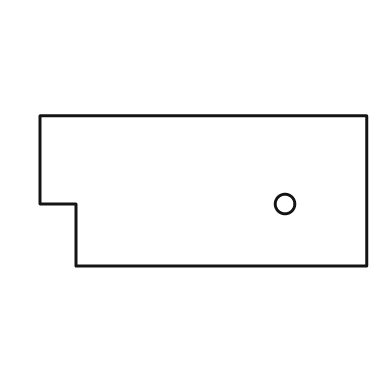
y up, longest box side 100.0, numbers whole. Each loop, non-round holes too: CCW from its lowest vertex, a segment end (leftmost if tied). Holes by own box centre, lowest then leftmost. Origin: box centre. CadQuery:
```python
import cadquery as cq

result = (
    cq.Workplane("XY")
    .moveTo(-39.0, -23.0)
    .lineTo(50.0, -23.0)
    .lineTo(50.0, 23.0)
    .lineTo(-50.0, 23.0)
    .lineTo(-50.0, -4.0)
    .lineTo(-39.0, -4.0)
    .close()
    .moveTo(25.0, -4.0)
    .circle(3.0)
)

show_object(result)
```